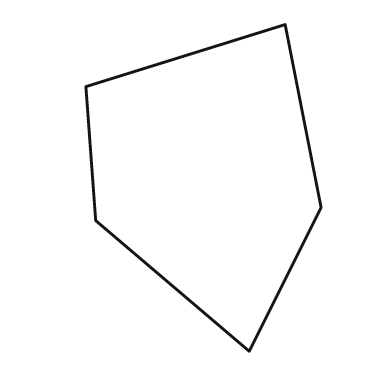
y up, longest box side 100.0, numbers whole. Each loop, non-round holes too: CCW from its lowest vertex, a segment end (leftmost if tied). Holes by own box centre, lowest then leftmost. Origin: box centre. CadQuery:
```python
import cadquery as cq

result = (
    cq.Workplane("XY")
    .moveTo(14.0, -50.0)
    .lineTo(36.0, -6.0)
    .lineTo(25.0, 50.0)
    .lineTo(-36.0, 31.0)
    .lineTo(-33.0, -10.0)
    .close()
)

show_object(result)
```